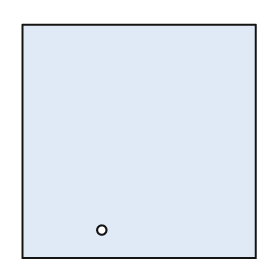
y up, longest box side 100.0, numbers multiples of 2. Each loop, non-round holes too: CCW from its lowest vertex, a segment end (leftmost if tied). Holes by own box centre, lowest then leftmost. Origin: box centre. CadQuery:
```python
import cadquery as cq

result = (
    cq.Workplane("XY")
    .moveTo(-50.0, -50.0)
    .lineTo(50.0, -50.0)
    .lineTo(50.0, 50.0)
    .lineTo(-50.0, 50.0)
    .close()
    .moveTo(-16.0, -38.0)
    .circle(2.0)
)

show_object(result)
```